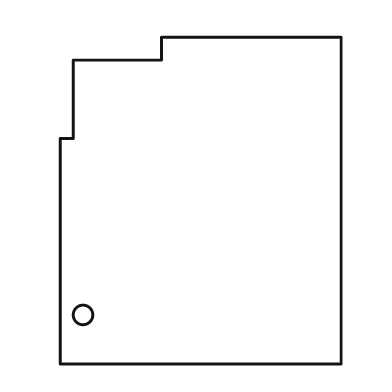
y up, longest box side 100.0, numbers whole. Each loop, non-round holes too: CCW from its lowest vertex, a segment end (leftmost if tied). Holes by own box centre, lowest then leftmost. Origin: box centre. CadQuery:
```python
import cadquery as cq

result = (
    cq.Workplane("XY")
    .moveTo(-43.0, -50.0)
    .lineTo(43.0, -50.0)
    .lineTo(43.0, 50.0)
    .lineTo(-12.0, 50.0)
    .lineTo(-12.0, 43.0)
    .lineTo(-39.0, 43.0)
    .lineTo(-39.0, 19.0)
    .lineTo(-43.0, 19.0)
    .close()
    .moveTo(-36.0, -35.0)
    .circle(3.0)
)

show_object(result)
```